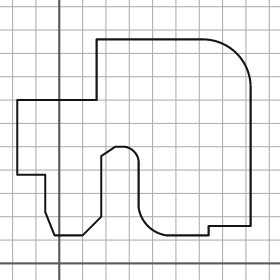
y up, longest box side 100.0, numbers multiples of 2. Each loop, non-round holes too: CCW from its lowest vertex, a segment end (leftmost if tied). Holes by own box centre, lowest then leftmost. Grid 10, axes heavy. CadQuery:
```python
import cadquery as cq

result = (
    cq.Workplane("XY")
    .moveTo(-2.0, 12.0)
    .lineTo(10.0, 12.0)
    .lineTo(18.0, 20.0)
    .lineTo(18.0, 46.0)
    .lineTo(24.0, 50.0)
    .lineTo(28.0, 50.0)
    .threePointArc((32.0, 48.0), (34.0, 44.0))
    .lineTo(34.0, 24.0)
    .threePointArc((38.0, 16.0), (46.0, 12.0))
    .lineTo(64.0, 12.0)
    .lineTo(64.0, 16.0)
    .lineTo(82.0, 16.0)
    .lineTo(82.0, 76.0)
    .threePointArc((76.0, 90.0), (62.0, 96.0))
    .lineTo(16.0, 96.0)
    .lineTo(16.0, 70.0)
    .lineTo(-18.0, 70.0)
    .lineTo(-18.0, 38.0)
    .lineTo(-6.0, 38.0)
    .lineTo(-6.0, 22.0)
    .close()
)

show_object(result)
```